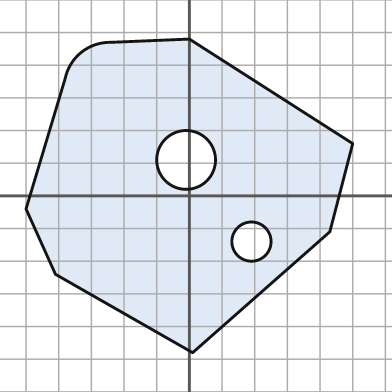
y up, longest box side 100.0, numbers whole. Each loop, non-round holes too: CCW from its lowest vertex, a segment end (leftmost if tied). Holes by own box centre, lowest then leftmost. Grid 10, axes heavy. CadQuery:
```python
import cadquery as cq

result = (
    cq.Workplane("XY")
    .moveTo(1.0, -48.0)
    .lineTo(43.0, -11.0)
    .lineTo(50.0, 16.0)
    .lineTo(0.0, 48.0)
    .lineTo(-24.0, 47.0)
    .threePointArc((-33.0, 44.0), (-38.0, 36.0))
    .lineTo(-50.0, -4.0)
    .lineTo(-41.0, -24.0)
    .close()
    .moveTo(19.0, -14.0)
    .circle(6.0)
    .moveTo(-1.0, 11.0)
    .circle(9.0)
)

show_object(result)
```